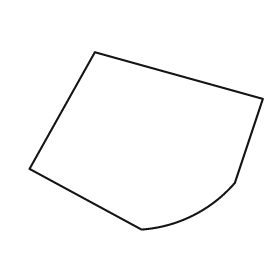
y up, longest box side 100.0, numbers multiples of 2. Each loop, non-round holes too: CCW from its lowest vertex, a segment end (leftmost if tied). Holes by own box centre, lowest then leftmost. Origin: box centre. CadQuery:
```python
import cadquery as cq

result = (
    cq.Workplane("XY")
    .moveTo(-2.0, -38.0)
    .threePointArc((20.0, -32.0), (38.0, -18.0))
    .lineTo(50.0, 18.0)
    .lineTo(-22.0, 38.0)
    .lineTo(-50.0, -12.0)
    .close()
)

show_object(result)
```